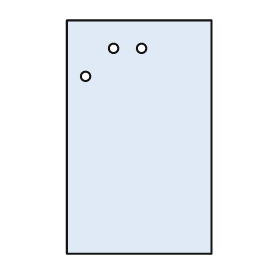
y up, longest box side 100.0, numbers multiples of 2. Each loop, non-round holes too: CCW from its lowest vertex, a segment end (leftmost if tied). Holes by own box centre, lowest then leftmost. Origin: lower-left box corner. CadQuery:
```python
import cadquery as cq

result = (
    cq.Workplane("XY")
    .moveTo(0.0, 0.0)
    .lineTo(62.0, 0.0)
    .lineTo(62.0, 100.0)
    .lineTo(0.0, 100.0)
    .close()
    .moveTo(8.0, 76.0)
    .circle(2.0)
    .moveTo(20.0, 88.0)
    .circle(2.0)
    .moveTo(32.0, 88.0)
    .circle(2.0)
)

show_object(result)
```